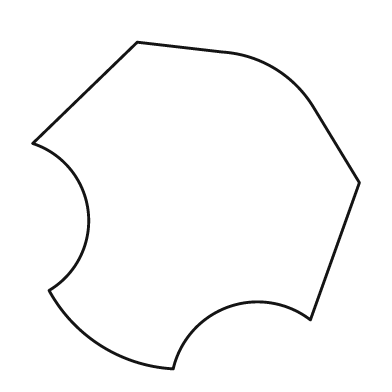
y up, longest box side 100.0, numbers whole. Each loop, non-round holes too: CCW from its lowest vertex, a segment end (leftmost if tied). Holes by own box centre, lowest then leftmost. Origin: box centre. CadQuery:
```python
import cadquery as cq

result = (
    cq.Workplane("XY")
    .moveTo(-7.0, -50.0)
    .threePointArc((10.0, -31.0), (35.0, -35.0))
    .lineTo(50.0, 7.0)
    .lineTo(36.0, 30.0)
    .threePointArc((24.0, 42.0), (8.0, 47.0))
    .lineTo(-18.0, 50.0)
    .lineTo(-50.0, 19.0)
    .threePointArc((-33.0, -2.0), (-45.0, -26.0))
    .threePointArc((-29.0, -43.0), (-7.0, -50.0))
    .close()
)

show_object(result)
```